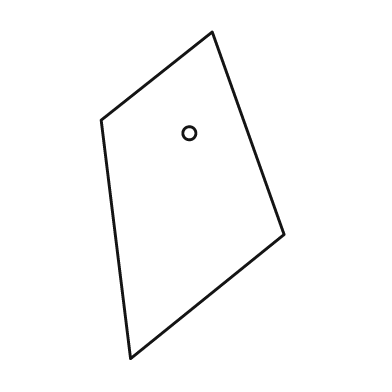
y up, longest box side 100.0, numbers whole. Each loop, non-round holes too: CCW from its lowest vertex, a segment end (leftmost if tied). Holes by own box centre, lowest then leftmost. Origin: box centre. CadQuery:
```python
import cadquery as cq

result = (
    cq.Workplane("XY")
    .moveTo(-19.0, -50.0)
    .lineTo(28.0, -12.0)
    .lineTo(6.0, 50.0)
    .lineTo(-28.0, 23.0)
    .close()
    .moveTo(-1.0, 19.0)
    .circle(2.0)
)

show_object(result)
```